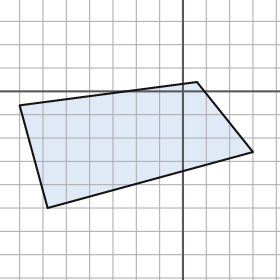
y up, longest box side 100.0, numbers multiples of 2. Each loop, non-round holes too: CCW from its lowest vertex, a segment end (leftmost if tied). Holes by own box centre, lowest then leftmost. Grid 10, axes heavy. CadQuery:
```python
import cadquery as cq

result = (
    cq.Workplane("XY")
    .moveTo(-58.0, -50.0)
    .lineTo(30.0, -26.0)
    .lineTo(6.0, 4.0)
    .lineTo(-70.0, -6.0)
    .close()
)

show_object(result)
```